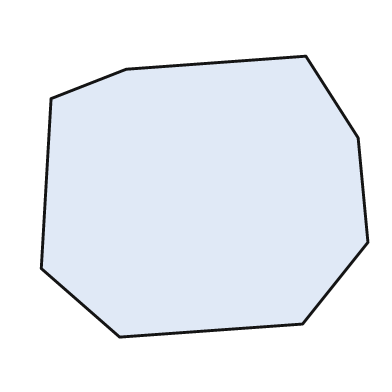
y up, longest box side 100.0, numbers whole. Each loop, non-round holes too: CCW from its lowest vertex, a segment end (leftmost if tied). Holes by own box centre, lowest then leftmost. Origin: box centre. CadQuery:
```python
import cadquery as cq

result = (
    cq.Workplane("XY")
    .moveTo(-26.0, -43.0)
    .lineTo(30.0, -39.0)
    .lineTo(50.0, -14.0)
    .lineTo(47.0, 18.0)
    .lineTo(31.0, 43.0)
    .lineTo(-24.0, 39.0)
    .lineTo(-47.0, 30.0)
    .lineTo(-50.0, -22.0)
    .close()
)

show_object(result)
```